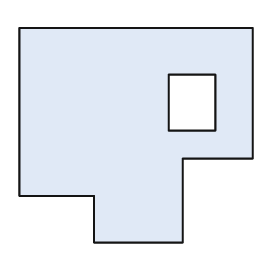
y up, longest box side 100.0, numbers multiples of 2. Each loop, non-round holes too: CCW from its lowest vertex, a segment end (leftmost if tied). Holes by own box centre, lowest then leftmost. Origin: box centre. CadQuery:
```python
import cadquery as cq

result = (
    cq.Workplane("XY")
    .moveTo(-18.0, -46.0)
    .lineTo(20.0, -46.0)
    .lineTo(20.0, -10.0)
    .lineTo(50.0, -10.0)
    .lineTo(50.0, 46.0)
    .lineTo(-50.0, 46.0)
    .lineTo(-50.0, -26.0)
    .lineTo(-18.0, -26.0)
    .close()
    .moveTo(14.0, 2.0)
    .lineTo(34.0, 2.0)
    .lineTo(34.0, 26.0)
    .lineTo(14.0, 26.0)
    .close()
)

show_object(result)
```